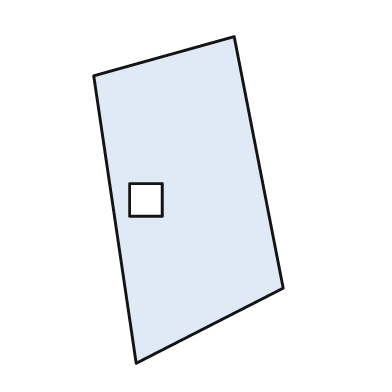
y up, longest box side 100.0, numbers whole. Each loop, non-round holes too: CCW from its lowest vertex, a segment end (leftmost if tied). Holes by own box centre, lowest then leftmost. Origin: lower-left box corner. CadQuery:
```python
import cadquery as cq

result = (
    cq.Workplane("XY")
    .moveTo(13.0, 0.0)
    .lineTo(58.0, 23.0)
    .lineTo(43.0, 100.0)
    .lineTo(0.0, 88.0)
    .close()
    .moveTo(11.0, 45.0)
    .lineTo(21.0, 45.0)
    .lineTo(21.0, 55.0)
    .lineTo(11.0, 55.0)
    .close()
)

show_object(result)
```